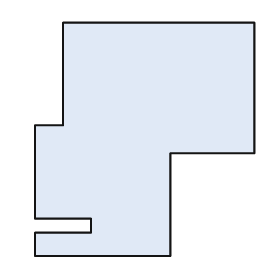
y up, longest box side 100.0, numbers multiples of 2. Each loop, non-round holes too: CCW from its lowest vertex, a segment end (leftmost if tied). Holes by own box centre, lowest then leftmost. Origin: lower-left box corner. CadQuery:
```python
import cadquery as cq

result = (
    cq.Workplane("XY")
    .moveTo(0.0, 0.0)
    .lineTo(58.0, 0.0)
    .lineTo(58.0, 44.0)
    .lineTo(94.0, 44.0)
    .lineTo(94.0, 100.0)
    .lineTo(12.0, 100.0)
    .lineTo(12.0, 56.0)
    .lineTo(0.0, 56.0)
    .lineTo(0.0, 16.0)
    .lineTo(24.0, 16.0)
    .lineTo(24.0, 10.0)
    .lineTo(0.0, 10.0)
    .close()
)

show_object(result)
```